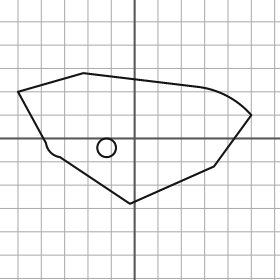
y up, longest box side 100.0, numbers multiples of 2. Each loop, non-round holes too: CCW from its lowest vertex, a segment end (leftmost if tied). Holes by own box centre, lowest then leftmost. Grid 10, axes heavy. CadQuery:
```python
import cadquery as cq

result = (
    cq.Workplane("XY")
    .moveTo(-2.0, -28.0)
    .lineTo(34.0, -12.0)
    .lineTo(50.0, 10.0)
    .threePointArc((40.0, 18.0), (28.0, 22.0))
    .lineTo(-22.0, 28.0)
    .lineTo(-50.0, 20.0)
    .lineTo(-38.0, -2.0)
    .threePointArc((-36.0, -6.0), (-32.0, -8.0))
    .close()
    .moveTo(-12.0, -4.0)
    .circle(4.0)
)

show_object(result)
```